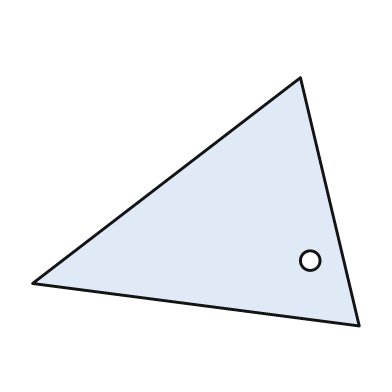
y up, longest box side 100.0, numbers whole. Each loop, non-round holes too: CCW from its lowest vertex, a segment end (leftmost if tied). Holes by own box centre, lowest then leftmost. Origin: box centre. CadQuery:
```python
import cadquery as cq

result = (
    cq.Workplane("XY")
    .moveTo(50.0, -38.0)
    .lineTo(32.0, 38.0)
    .lineTo(-50.0, -25.0)
    .close()
    .moveTo(35.0, -18.0)
    .circle(3.0)
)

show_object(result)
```